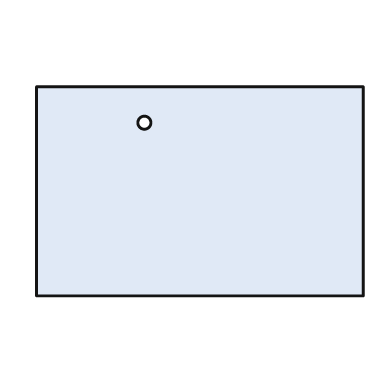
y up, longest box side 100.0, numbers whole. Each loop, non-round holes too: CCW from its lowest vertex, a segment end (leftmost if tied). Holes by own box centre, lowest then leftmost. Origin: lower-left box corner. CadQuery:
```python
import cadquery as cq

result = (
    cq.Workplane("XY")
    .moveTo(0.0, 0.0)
    .lineTo(100.0, 0.0)
    .lineTo(100.0, 64.0)
    .lineTo(0.0, 64.0)
    .close()
    .moveTo(33.0, 53.0)
    .circle(2.0)
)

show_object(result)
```